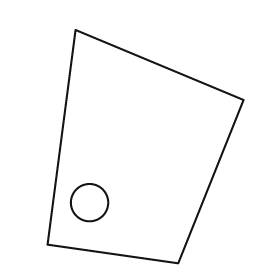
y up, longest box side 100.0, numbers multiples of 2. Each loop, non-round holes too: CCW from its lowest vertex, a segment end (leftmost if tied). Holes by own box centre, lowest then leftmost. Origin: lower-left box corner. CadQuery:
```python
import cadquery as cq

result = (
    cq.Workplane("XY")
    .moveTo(56.0, 0.0)
    .lineTo(84.0, 70.0)
    .lineTo(12.0, 100.0)
    .lineTo(0.0, 8.0)
    .close()
    .moveTo(18.0, 26.0)
    .circle(8.0)
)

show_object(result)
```